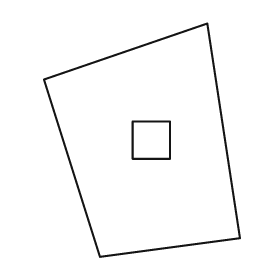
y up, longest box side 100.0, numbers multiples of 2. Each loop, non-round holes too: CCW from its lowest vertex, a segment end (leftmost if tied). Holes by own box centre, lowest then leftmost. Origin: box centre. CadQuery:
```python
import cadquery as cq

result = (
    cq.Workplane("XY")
    .moveTo(-18.0, -50.0)
    .lineTo(42.0, -42.0)
    .lineTo(28.0, 50.0)
    .lineTo(-42.0, 26.0)
    .close()
    .moveTo(-4.0, -8.0)
    .lineTo(12.0, -8.0)
    .lineTo(12.0, 8.0)
    .lineTo(-4.0, 8.0)
    .close()
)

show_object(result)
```